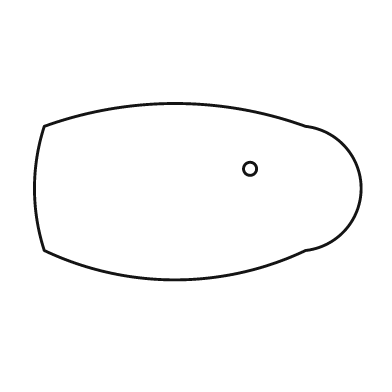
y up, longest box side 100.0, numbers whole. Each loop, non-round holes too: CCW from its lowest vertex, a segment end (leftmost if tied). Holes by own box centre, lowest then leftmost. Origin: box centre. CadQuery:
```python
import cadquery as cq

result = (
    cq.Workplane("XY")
    .moveTo(-47.0, -18.0)
    .threePointArc((-7.0, -27.0), (33.0, -18.0))
    .threePointArc((50.0, 1.0), (33.0, 20.0))
    .threePointArc((-7.0, 27.0), (-47.0, 20.0))
    .threePointArc((-50.0, 1.0), (-47.0, -18.0))
    .close()
    .moveTo(16.0, 7.0)
    .circle(2.0)
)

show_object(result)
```